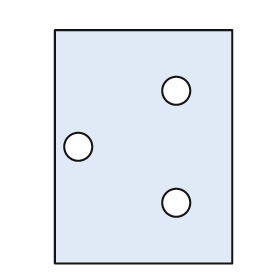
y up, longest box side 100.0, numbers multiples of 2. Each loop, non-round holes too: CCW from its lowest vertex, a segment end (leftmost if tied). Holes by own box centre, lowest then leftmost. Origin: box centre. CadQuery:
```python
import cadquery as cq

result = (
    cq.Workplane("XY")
    .moveTo(-38.0, -50.0)
    .lineTo(38.0, -50.0)
    .lineTo(38.0, 50.0)
    .lineTo(-38.0, 50.0)
    .close()
    .moveTo(14.0, -24.0)
    .circle(6.0)
    .moveTo(-28.0, 0.0)
    .circle(6.0)
    .moveTo(14.0, 24.0)
    .circle(6.0)
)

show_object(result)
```